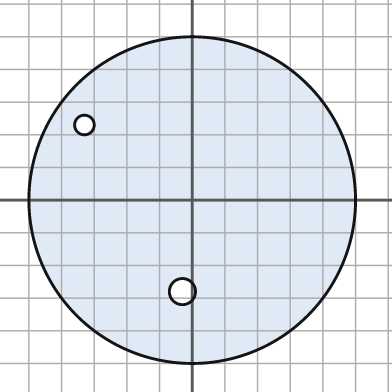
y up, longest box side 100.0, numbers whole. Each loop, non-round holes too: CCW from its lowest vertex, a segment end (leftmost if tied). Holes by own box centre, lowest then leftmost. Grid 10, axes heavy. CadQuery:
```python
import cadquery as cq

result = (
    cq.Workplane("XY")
    .moveTo(0.0, 0.0)
    .circle(50.0)
    .moveTo(-3.0, -28.0)
    .circle(4.0)
    .moveTo(-33.0, 23.0)
    .circle(3.0)
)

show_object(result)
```